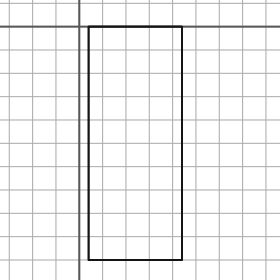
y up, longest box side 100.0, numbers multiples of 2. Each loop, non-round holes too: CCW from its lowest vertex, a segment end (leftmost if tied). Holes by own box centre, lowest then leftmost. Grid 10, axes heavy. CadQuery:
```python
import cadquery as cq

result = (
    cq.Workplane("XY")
    .moveTo(4.0, -100.0)
    .lineTo(44.0, -100.0)
    .lineTo(44.0, 0.0)
    .lineTo(4.0, 0.0)
    .close()
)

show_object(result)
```